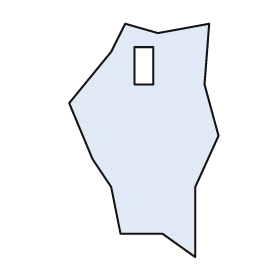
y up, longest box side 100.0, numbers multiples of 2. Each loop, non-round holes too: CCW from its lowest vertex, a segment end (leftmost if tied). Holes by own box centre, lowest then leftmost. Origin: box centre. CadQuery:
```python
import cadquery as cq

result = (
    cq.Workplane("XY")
    .moveTo(22.0, -50.0)
    .lineTo(22.0, -20.0)
    .lineTo(32.0, 2.0)
    .lineTo(26.0, 24.0)
    .lineTo(28.0, 50.0)
    .lineTo(6.0, 46.0)
    .lineTo(-8.0, 50.0)
    .lineTo(-14.0, 38.0)
    .lineTo(-32.0, 16.0)
    .lineTo(-22.0, -8.0)
    .lineTo(-14.0, -20.0)
    .lineTo(-10.0, -40.0)
    .lineTo(8.0, -40.0)
    .close()
    .moveTo(-4.0, 24.0)
    .lineTo(4.0, 24.0)
    .lineTo(4.0, 40.0)
    .lineTo(-4.0, 40.0)
    .close()
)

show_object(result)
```